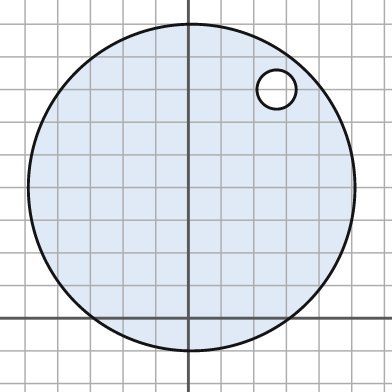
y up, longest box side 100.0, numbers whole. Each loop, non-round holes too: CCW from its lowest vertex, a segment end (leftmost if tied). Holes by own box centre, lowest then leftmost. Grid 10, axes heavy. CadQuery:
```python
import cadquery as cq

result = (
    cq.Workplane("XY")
    .moveTo(1.0, 40.0)
    .circle(50.0)
    .moveTo(27.0, 70.0)
    .circle(6.0)
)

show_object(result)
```